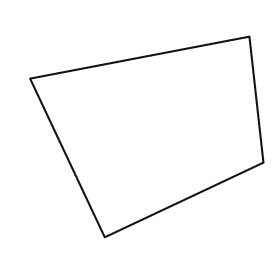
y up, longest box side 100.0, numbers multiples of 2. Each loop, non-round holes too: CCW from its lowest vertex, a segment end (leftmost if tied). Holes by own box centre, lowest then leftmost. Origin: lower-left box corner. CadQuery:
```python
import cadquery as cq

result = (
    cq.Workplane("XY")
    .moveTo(32.0, 0.0)
    .lineTo(100.0, 32.0)
    .lineTo(94.0, 86.0)
    .lineTo(0.0, 68.0)
    .close()
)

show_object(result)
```